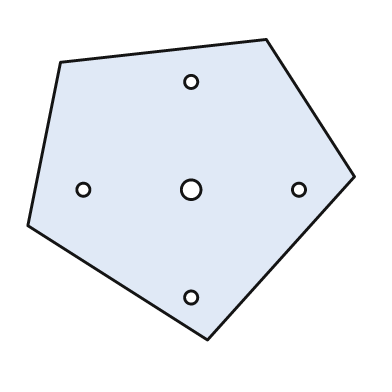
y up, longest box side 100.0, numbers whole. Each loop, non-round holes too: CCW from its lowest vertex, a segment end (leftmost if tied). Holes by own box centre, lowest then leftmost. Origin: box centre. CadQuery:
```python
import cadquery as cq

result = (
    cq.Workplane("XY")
    .moveTo(5.0, -46.0)
    .lineTo(50.0, 4.0)
    .lineTo(23.0, 46.0)
    .lineTo(-40.0, 39.0)
    .lineTo(-50.0, -11.0)
    .close()
    .moveTo(0.0, -33.0)
    .circle(2.0)
    .moveTo(-33.0, 0.0)
    .circle(2.0)
    .moveTo(0.0, 0.0)
    .circle(3.0)
    .moveTo(33.0, 0.0)
    .circle(2.0)
    .moveTo(0.0, 33.0)
    .circle(2.0)
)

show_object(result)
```